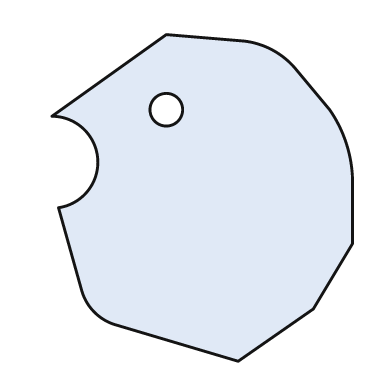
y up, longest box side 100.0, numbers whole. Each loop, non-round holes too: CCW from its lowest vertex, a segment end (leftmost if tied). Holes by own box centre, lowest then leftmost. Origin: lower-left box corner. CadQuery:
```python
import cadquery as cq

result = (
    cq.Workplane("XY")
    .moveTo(57.0, 0.0)
    .lineTo(80.0, 16.0)
    .lineTo(92.0, 36.0)
    .lineTo(92.0, 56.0)
    .threePointArc((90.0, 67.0), (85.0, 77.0))
    .lineTo(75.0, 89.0)
    .threePointArc((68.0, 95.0), (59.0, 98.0))
    .lineTo(35.0, 100.0)
    .lineTo(0.0, 75.0)
    .threePointArc((14.0, 62.0), (2.0, 47.0))
    .lineTo(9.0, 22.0)
    .threePointArc((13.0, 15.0), (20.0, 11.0))
    .close()
    .moveTo(35.0, 77.0)
    .circle(5.0)
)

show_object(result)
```